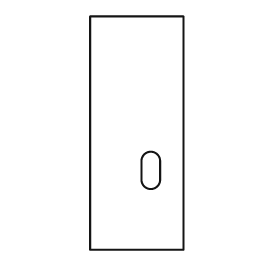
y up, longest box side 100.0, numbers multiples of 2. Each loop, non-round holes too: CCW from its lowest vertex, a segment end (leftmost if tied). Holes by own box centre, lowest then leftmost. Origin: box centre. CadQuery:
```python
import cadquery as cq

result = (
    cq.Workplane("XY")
    .moveTo(-20.0, -50.0)
    .lineTo(20.0, -50.0)
    .lineTo(20.0, 50.0)
    .lineTo(-20.0, 50.0)
    .close()
    .moveTo(2.0, -20.0)
    .threePointArc((6.0, -24.0), (10.0, -20.0))
    .lineTo(10.0, -12.0)
    .threePointArc((6.0, -8.0), (2.0, -12.0))
    .close()
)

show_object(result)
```